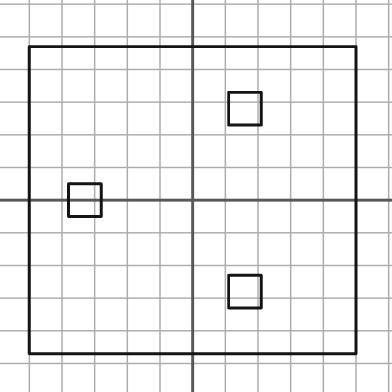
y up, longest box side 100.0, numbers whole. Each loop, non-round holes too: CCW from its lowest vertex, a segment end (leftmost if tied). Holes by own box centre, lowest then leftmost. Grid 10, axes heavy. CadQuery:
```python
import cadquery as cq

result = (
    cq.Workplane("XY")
    .moveTo(-50.0, -47.0)
    .lineTo(50.0, -47.0)
    .lineTo(50.0, 47.0)
    .lineTo(-50.0, 47.0)
    .close()
    .moveTo(11.0, -33.0)
    .lineTo(21.0, -33.0)
    .lineTo(21.0, -23.0)
    .lineTo(11.0, -23.0)
    .close()
    .moveTo(-38.0, -5.0)
    .lineTo(-28.0, -5.0)
    .lineTo(-28.0, 5.0)
    .lineTo(-38.0, 5.0)
    .close()
    .moveTo(11.0, 23.0)
    .lineTo(21.0, 23.0)
    .lineTo(21.0, 33.0)
    .lineTo(11.0, 33.0)
    .close()
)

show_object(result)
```